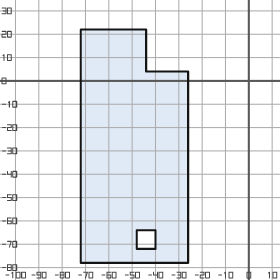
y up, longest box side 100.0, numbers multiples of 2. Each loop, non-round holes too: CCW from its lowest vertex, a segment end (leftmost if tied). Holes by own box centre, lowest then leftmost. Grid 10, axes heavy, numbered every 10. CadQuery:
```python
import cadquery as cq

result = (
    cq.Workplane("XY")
    .moveTo(-72.0, -78.0)
    .lineTo(-26.0, -78.0)
    .lineTo(-26.0, 4.0)
    .lineTo(-44.0, 4.0)
    .lineTo(-44.0, 22.0)
    .lineTo(-72.0, 22.0)
    .close()
    .moveTo(-48.0, -72.0)
    .lineTo(-40.0, -72.0)
    .lineTo(-40.0, -64.0)
    .lineTo(-48.0, -64.0)
    .close()
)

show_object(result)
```